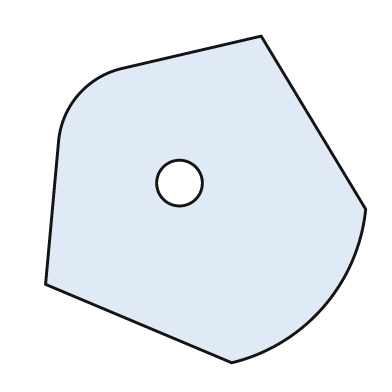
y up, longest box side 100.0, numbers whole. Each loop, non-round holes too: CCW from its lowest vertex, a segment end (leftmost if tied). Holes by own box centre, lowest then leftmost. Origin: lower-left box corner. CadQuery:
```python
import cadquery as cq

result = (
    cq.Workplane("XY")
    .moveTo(57.0, 0.0)
    .threePointArc((85.0, 17.0), (98.0, 47.0))
    .lineTo(66.0, 100.0)
    .lineTo(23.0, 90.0)
    .threePointArc((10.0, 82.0), (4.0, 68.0))
    .lineTo(0.0, 24.0)
    .close()
    .moveTo(41.0, 55.0)
    .circle(7.0)
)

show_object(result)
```